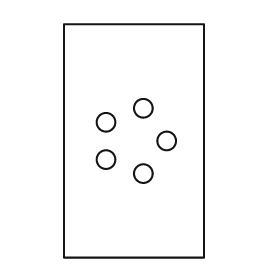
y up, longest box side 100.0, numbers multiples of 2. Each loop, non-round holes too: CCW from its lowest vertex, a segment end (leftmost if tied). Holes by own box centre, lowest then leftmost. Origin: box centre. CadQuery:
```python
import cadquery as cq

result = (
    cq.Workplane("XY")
    .moveTo(-30.0, -50.0)
    .lineTo(30.0, -50.0)
    .lineTo(30.0, 50.0)
    .lineTo(-30.0, 50.0)
    .close()
    .moveTo(4.0, -14.0)
    .circle(4.0)
    .moveTo(-12.0, -8.0)
    .circle(4.0)
    .moveTo(14.0, 0.0)
    .circle(4.0)
    .moveTo(-12.0, 8.0)
    .circle(4.0)
    .moveTo(4.0, 14.0)
    .circle(4.0)
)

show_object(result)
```